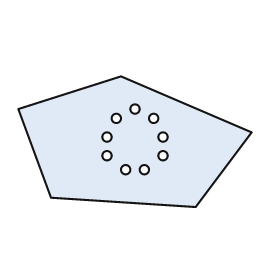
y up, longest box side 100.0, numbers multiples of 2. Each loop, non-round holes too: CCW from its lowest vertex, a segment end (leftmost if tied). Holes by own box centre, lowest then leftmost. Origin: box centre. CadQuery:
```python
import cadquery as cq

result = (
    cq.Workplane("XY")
    .moveTo(26.0, -28.0)
    .lineTo(50.0, 4.0)
    .lineTo(-6.0, 28.0)
    .lineTo(-50.0, 14.0)
    .lineTo(-36.0, -24.0)
    .close()
    .moveTo(-4.0, -12.0)
    .circle(2.0)
    .moveTo(4.0, -12.0)
    .circle(2.0)
    .moveTo(-12.0, -6.0)
    .circle(2.0)
    .moveTo(12.0, -6.0)
    .circle(2.0)
    .moveTo(-12.0, 2.0)
    .circle(2.0)
    .moveTo(12.0, 2.0)
    .circle(2.0)
    .moveTo(-8.0, 10.0)
    .circle(2.0)
    .moveTo(8.0, 10.0)
    .circle(2.0)
    .moveTo(0.0, 14.0)
    .circle(2.0)
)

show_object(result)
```